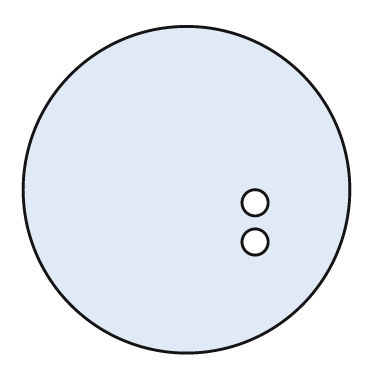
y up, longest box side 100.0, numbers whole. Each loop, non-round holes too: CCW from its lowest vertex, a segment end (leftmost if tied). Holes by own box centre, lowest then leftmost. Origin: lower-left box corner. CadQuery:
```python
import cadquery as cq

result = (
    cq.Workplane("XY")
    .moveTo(50.0, 50.0)
    .circle(50.0)
    .moveTo(71.0, 34.0)
    .circle(4.0)
    .moveTo(71.0, 46.0)
    .circle(4.0)
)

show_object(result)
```